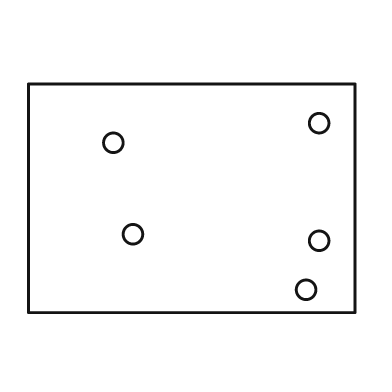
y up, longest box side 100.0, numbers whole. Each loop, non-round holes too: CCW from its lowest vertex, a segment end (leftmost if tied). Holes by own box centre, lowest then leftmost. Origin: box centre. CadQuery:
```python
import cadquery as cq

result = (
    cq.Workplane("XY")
    .moveTo(-50.0, -35.0)
    .lineTo(50.0, -35.0)
    .lineTo(50.0, 35.0)
    .lineTo(-50.0, 35.0)
    .close()
    .moveTo(35.0, -28.0)
    .circle(3.0)
    .moveTo(39.0, -13.0)
    .circle(3.0)
    .moveTo(-18.0, -11.0)
    .circle(3.0)
    .moveTo(-24.0, 17.0)
    .circle(3.0)
    .moveTo(39.0, 23.0)
    .circle(3.0)
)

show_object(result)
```